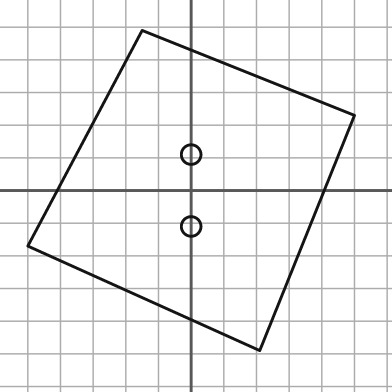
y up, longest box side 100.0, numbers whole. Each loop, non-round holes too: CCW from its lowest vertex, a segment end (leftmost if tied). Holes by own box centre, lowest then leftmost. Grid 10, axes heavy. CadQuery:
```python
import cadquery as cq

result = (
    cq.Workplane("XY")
    .moveTo(21.0, -49.0)
    .lineTo(50.0, 23.0)
    .lineTo(-15.0, 49.0)
    .lineTo(-50.0, -17.0)
    .close()
    .moveTo(0.0, -11.0)
    .circle(3.0)
    .moveTo(0.0, 11.0)
    .circle(3.0)
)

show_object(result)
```